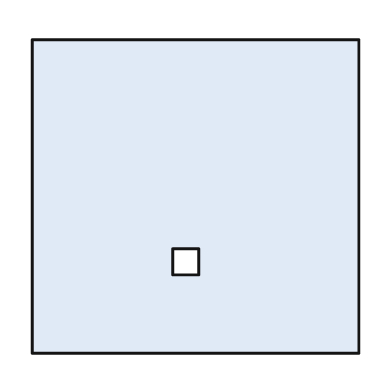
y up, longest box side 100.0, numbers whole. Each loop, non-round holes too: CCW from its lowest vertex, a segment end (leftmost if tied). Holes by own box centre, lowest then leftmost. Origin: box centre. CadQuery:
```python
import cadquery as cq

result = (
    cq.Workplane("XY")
    .moveTo(-50.0, -48.0)
    .lineTo(50.0, -48.0)
    .lineTo(50.0, 48.0)
    .lineTo(-50.0, 48.0)
    .close()
    .moveTo(-7.0, -24.0)
    .lineTo(1.0, -24.0)
    .lineTo(1.0, -16.0)
    .lineTo(-7.0, -16.0)
    .close()
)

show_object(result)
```